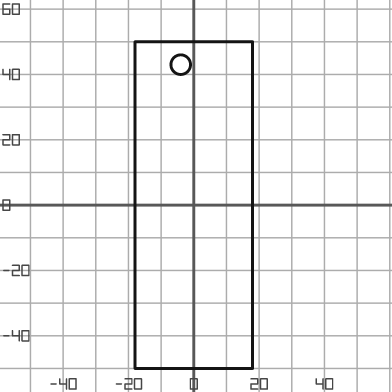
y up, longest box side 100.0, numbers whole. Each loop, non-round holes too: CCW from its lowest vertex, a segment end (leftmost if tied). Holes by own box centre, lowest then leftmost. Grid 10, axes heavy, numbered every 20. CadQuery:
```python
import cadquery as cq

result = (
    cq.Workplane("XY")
    .moveTo(-18.0, -50.0)
    .lineTo(18.0, -50.0)
    .lineTo(18.0, 50.0)
    .lineTo(-18.0, 50.0)
    .close()
    .moveTo(-4.0, 43.0)
    .circle(3.0)
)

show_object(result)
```